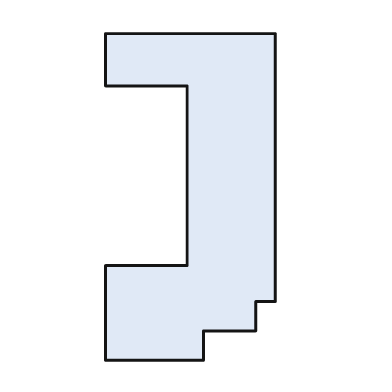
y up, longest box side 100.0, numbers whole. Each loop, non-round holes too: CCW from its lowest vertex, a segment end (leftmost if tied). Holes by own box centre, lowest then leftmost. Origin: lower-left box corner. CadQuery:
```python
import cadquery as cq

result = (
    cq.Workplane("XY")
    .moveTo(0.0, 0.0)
    .lineTo(30.0, 0.0)
    .lineTo(30.0, 9.0)
    .lineTo(46.0, 9.0)
    .lineTo(46.0, 18.0)
    .lineTo(52.0, 18.0)
    .lineTo(52.0, 100.0)
    .lineTo(0.0, 100.0)
    .lineTo(0.0, 84.0)
    .lineTo(25.0, 84.0)
    .lineTo(25.0, 29.0)
    .lineTo(0.0, 29.0)
    .close()
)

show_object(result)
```